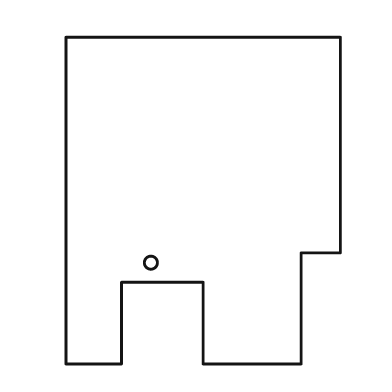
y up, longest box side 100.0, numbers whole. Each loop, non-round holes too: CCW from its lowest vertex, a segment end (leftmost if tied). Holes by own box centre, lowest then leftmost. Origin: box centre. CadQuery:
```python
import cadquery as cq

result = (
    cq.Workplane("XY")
    .moveTo(-42.0, -50.0)
    .lineTo(-25.0, -50.0)
    .lineTo(-25.0, -25.0)
    .lineTo(0.0, -25.0)
    .lineTo(0.0, -50.0)
    .lineTo(30.0, -50.0)
    .lineTo(30.0, -16.0)
    .lineTo(42.0, -16.0)
    .lineTo(42.0, 50.0)
    .lineTo(-42.0, 50.0)
    .close()
    .moveTo(-16.0, -19.0)
    .circle(2.0)
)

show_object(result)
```